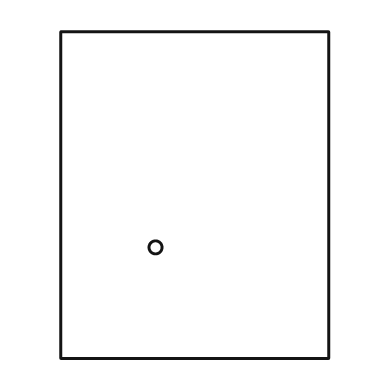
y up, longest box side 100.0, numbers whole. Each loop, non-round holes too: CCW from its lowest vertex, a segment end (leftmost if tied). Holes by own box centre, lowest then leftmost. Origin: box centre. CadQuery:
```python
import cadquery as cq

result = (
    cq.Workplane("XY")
    .moveTo(-41.0, -50.0)
    .lineTo(41.0, -50.0)
    .lineTo(41.0, 50.0)
    .lineTo(-41.0, 50.0)
    .close()
    .moveTo(-12.0, -16.0)
    .circle(2.0)
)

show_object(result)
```